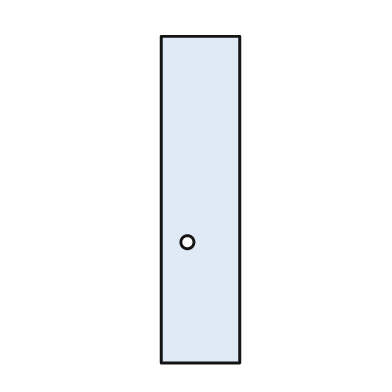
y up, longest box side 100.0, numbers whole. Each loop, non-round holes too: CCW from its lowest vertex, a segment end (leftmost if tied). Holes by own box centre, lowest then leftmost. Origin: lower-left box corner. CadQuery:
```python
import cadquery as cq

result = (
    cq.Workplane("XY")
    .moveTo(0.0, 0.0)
    .lineTo(24.0, 0.0)
    .lineTo(24.0, 100.0)
    .lineTo(0.0, 100.0)
    .close()
    .moveTo(8.0, 37.0)
    .circle(2.0)
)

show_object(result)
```